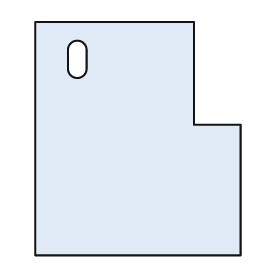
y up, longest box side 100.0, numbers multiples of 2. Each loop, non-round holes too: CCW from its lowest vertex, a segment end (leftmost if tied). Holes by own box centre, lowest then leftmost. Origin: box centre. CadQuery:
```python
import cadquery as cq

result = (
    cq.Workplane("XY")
    .moveTo(-44.0, -50.0)
    .lineTo(44.0, -50.0)
    .lineTo(44.0, 6.0)
    .lineTo(24.0, 6.0)
    .lineTo(24.0, 50.0)
    .lineTo(-44.0, 50.0)
    .close()
    .moveTo(-30.0, 30.0)
    .threePointArc((-26.0, 26.0), (-22.0, 30.0))
    .lineTo(-22.0, 38.0)
    .threePointArc((-26.0, 42.0), (-30.0, 38.0))
    .close()
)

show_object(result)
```